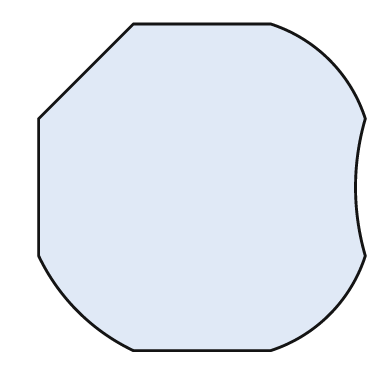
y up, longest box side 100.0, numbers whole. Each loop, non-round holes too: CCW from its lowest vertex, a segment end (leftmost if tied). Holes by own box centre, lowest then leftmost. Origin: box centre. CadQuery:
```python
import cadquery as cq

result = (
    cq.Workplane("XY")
    .moveTo(-21.0, -50.0)
    .lineTo(21.0, -50.0)
    .threePointArc((39.0, -39.0), (50.0, -21.0))
    .threePointArc((47.0, 0.0), (50.0, 21.0))
    .threePointArc((39.0, 39.0), (21.0, 50.0))
    .lineTo(-21.0, 50.0)
    .lineTo(-50.0, 21.0)
    .lineTo(-50.0, -21.0)
    .threePointArc((-38.0, -38.0), (-21.0, -50.0))
    .close()
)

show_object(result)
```